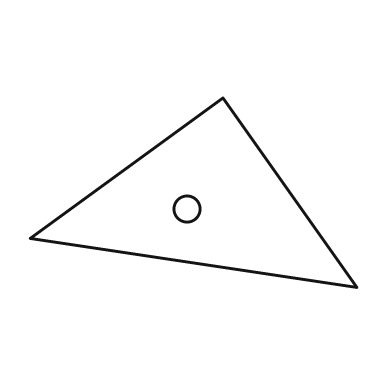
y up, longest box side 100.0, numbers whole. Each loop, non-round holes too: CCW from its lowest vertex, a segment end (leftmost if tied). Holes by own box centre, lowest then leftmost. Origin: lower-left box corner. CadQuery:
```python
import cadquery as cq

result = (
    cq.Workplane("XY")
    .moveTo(100.0, 0.0)
    .lineTo(59.0, 58.0)
    .lineTo(0.0, 15.0)
    .close()
    .moveTo(48.0, 24.0)
    .circle(4.0)
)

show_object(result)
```